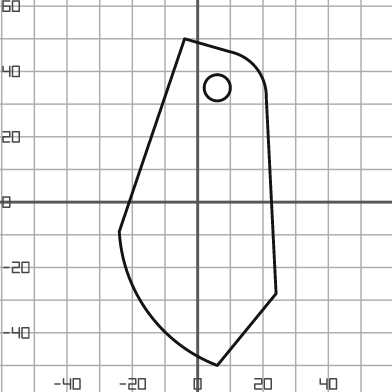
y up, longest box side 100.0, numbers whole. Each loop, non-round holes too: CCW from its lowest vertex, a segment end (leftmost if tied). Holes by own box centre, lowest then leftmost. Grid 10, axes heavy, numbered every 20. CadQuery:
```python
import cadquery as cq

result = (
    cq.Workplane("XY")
    .moveTo(6.0, -50.0)
    .lineTo(24.0, -28.0)
    .lineTo(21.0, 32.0)
    .threePointArc((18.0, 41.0), (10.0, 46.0))
    .lineTo(-4.0, 50.0)
    .lineTo(-24.0, -9.0)
    .threePointArc((-15.0, -34.0), (6.0, -50.0))
    .close()
    .moveTo(6.0, 35.0)
    .circle(4.0)
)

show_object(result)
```